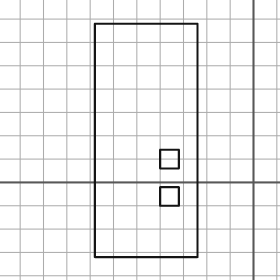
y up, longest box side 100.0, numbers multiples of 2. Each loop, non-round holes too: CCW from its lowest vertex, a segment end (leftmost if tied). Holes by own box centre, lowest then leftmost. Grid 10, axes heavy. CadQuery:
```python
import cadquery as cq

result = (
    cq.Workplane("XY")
    .moveTo(-68.0, -32.0)
    .lineTo(-24.0, -32.0)
    .lineTo(-24.0, 68.0)
    .lineTo(-68.0, 68.0)
    .close()
    .moveTo(-40.0, -10.0)
    .lineTo(-32.0, -10.0)
    .lineTo(-32.0, -2.0)
    .lineTo(-40.0, -2.0)
    .close()
    .moveTo(-40.0, 6.0)
    .lineTo(-32.0, 6.0)
    .lineTo(-32.0, 14.0)
    .lineTo(-40.0, 14.0)
    .close()
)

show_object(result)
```